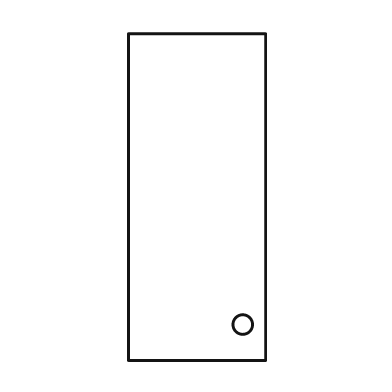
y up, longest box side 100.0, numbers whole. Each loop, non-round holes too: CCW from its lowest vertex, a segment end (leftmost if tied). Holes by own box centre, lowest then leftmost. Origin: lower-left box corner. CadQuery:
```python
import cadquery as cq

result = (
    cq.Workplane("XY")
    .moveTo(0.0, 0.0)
    .lineTo(42.0, 0.0)
    .lineTo(42.0, 100.0)
    .lineTo(0.0, 100.0)
    .close()
    .moveTo(35.0, 11.0)
    .circle(3.0)
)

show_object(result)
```